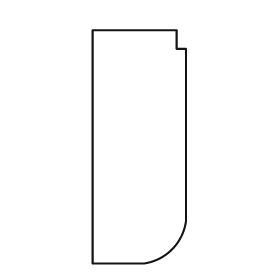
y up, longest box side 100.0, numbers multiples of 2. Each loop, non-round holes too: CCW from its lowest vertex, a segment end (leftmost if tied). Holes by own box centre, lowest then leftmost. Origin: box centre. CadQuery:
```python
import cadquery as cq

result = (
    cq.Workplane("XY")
    .moveTo(-20.0, -50.0)
    .lineTo(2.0, -50.0)
    .threePointArc((14.0, -44.0), (20.0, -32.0))
    .lineTo(20.0, 42.0)
    .lineTo(16.0, 42.0)
    .lineTo(16.0, 50.0)
    .lineTo(-20.0, 50.0)
    .close()
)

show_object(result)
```